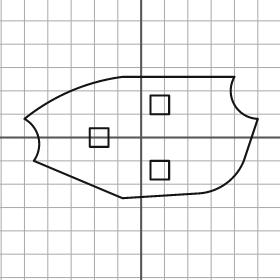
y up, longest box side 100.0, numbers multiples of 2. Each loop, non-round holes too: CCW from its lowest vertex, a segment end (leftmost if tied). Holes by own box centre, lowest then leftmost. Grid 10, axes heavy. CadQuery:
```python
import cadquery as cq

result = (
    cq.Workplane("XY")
    .moveTo(-8.0, -26.0)
    .lineTo(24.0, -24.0)
    .threePointArc((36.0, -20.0), (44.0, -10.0))
    .lineTo(50.0, 8.0)
    .threePointArc((40.0, 14.0), (40.0, 26.0))
    .lineTo(-8.0, 26.0)
    .threePointArc((-30.0, 20.0), (-50.0, 8.0))
    .threePointArc((-44.0, 0.0), (-46.0, -10.0))
    .close()
    .moveTo(4.0, -18.0)
    .lineTo(12.0, -18.0)
    .lineTo(12.0, -10.0)
    .lineTo(4.0, -10.0)
    .close()
    .moveTo(-22.0, -4.0)
    .lineTo(-14.0, -4.0)
    .lineTo(-14.0, 4.0)
    .lineTo(-22.0, 4.0)
    .close()
    .moveTo(4.0, 10.0)
    .lineTo(12.0, 10.0)
    .lineTo(12.0, 18.0)
    .lineTo(4.0, 18.0)
    .close()
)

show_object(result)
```